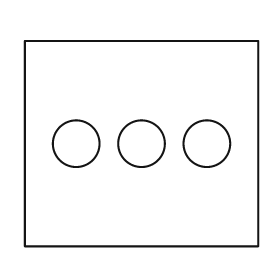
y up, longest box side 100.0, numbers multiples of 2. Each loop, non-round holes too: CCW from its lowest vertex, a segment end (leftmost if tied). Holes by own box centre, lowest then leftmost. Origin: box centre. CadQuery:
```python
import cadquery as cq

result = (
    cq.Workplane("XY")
    .moveTo(-50.0, -44.0)
    .lineTo(50.0, -44.0)
    .lineTo(50.0, 44.0)
    .lineTo(-50.0, 44.0)
    .close()
    .moveTo(-28.0, 0.0)
    .circle(10.0)
    .moveTo(0.0, 0.0)
    .circle(10.0)
    .moveTo(28.0, 0.0)
    .circle(10.0)
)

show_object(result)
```